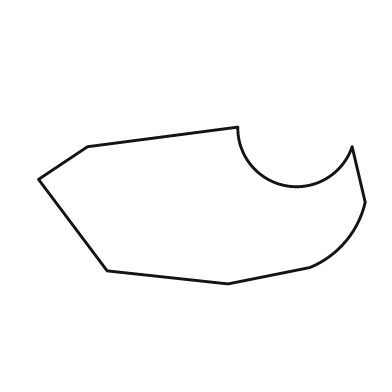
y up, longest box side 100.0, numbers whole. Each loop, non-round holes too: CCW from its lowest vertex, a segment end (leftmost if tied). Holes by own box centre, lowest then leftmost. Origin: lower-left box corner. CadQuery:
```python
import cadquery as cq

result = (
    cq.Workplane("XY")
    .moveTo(58.0, 0.0)
    .lineTo(83.0, 5.0)
    .threePointArc((94.0, 13.0), (100.0, 25.0))
    .lineTo(96.0, 42.0)
    .threePointArc((76.0, 30.0), (61.0, 48.0))
    .lineTo(15.0, 42.0)
    .lineTo(0.0, 32.0)
    .lineTo(21.0, 4.0)
    .close()
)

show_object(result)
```